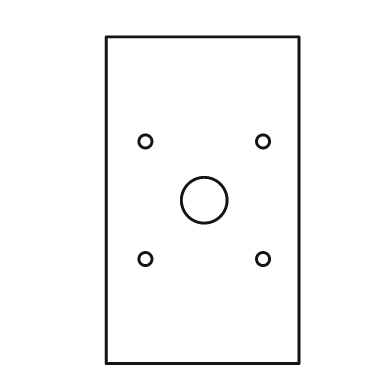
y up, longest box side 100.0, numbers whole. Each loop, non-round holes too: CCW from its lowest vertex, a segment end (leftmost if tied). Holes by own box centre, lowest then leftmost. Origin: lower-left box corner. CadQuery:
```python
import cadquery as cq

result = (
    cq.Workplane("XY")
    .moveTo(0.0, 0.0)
    .lineTo(59.0, 0.0)
    .lineTo(59.0, 100.0)
    .lineTo(0.0, 100.0)
    .close()
    .moveTo(12.0, 32.0)
    .circle(2.0)
    .moveTo(48.0, 32.0)
    .circle(2.0)
    .moveTo(30.0, 50.0)
    .circle(7.0)
    .moveTo(12.0, 68.0)
    .circle(2.0)
    .moveTo(48.0, 68.0)
    .circle(2.0)
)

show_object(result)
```